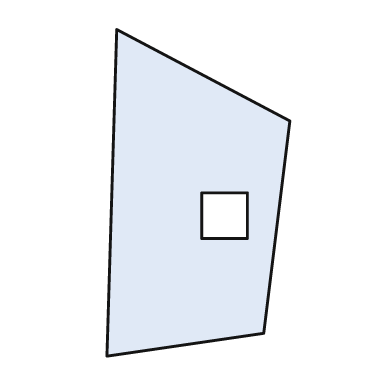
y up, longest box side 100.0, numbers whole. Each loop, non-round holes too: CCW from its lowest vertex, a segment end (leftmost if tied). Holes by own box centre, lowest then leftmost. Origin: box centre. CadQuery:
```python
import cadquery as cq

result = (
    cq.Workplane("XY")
    .moveTo(-28.0, -50.0)
    .lineTo(20.0, -43.0)
    .lineTo(28.0, 22.0)
    .lineTo(-25.0, 50.0)
    .close()
    .moveTo(1.0, -14.0)
    .lineTo(15.0, -14.0)
    .lineTo(15.0, 0.0)
    .lineTo(1.0, 0.0)
    .close()
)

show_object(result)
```